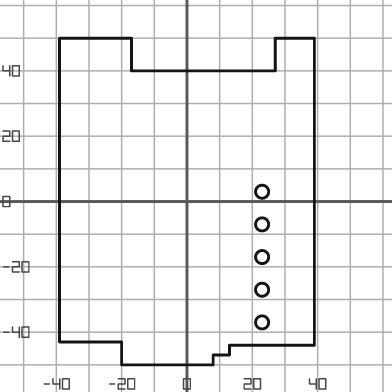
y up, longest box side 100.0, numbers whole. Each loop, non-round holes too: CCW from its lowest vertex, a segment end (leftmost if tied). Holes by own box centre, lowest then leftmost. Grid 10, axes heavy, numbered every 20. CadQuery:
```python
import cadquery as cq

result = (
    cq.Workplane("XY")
    .moveTo(-20.0, -50.0)
    .lineTo(8.0, -50.0)
    .lineTo(8.0, -47.0)
    .lineTo(13.0, -47.0)
    .lineTo(13.0, -44.0)
    .lineTo(39.0, -44.0)
    .lineTo(39.0, 50.0)
    .lineTo(27.0, 50.0)
    .lineTo(27.0, 40.0)
    .lineTo(-17.0, 40.0)
    .lineTo(-17.0, 50.0)
    .lineTo(-39.0, 50.0)
    .lineTo(-39.0, -43.0)
    .lineTo(-20.0, -43.0)
    .close()
    .moveTo(23.0, -37.0)
    .circle(2.0)
    .moveTo(23.0, -27.0)
    .circle(2.0)
    .moveTo(23.0, -17.0)
    .circle(2.0)
    .moveTo(23.0, -7.0)
    .circle(2.0)
    .moveTo(23.0, 3.0)
    .circle(2.0)
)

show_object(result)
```